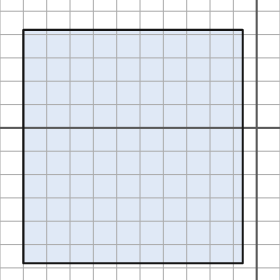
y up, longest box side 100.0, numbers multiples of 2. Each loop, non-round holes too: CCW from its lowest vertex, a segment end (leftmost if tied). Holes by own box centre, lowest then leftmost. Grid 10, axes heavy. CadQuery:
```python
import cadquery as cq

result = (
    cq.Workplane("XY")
    .moveTo(-100.0, -58.0)
    .lineTo(-6.0, -58.0)
    .lineTo(-6.0, 42.0)
    .lineTo(-100.0, 42.0)
    .close()
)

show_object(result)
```